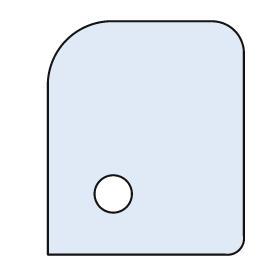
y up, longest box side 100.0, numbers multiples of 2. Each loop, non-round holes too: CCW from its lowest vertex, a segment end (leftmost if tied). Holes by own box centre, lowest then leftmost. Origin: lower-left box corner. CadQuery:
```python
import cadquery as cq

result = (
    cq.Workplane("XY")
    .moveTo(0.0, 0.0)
    .lineTo(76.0, 0.0)
    .threePointArc((82.0, 2.0), (84.0, 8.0))
    .lineTo(84.0, 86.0)
    .threePointArc((80.0, 96.0), (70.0, 100.0))
    .lineTo(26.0, 100.0)
    .threePointArc((8.0, 92.0), (0.0, 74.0))
    .close()
    .moveTo(28.0, 26.0)
    .circle(8.0)
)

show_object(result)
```